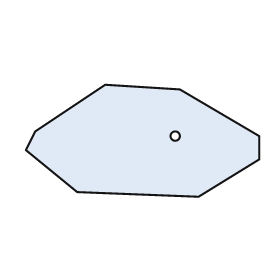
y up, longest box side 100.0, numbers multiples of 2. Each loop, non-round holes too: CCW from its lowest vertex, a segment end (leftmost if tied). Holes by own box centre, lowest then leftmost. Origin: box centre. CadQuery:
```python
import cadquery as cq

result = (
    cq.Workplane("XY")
    .moveTo(24.0, -24.0)
    .lineTo(50.0, -8.0)
    .lineTo(50.0, 2.0)
    .lineTo(16.0, 22.0)
    .lineTo(-16.0, 24.0)
    .lineTo(-46.0, 4.0)
    .lineTo(-50.0, -4.0)
    .lineTo(-28.0, -22.0)
    .close()
    .moveTo(14.0, 2.0)
    .circle(2.0)
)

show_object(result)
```